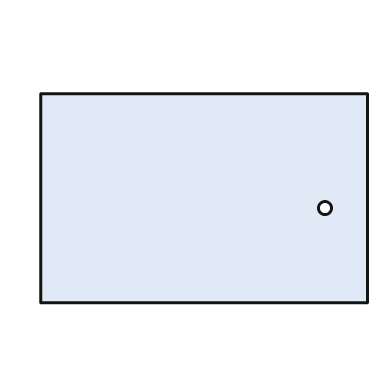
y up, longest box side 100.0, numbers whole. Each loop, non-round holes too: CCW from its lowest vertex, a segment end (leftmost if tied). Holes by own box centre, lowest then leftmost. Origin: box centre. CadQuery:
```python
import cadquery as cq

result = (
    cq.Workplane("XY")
    .moveTo(-50.0, -32.0)
    .lineTo(50.0, -32.0)
    .lineTo(50.0, 32.0)
    .lineTo(-50.0, 32.0)
    .close()
    .moveTo(37.0, -3.0)
    .circle(2.0)
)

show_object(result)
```